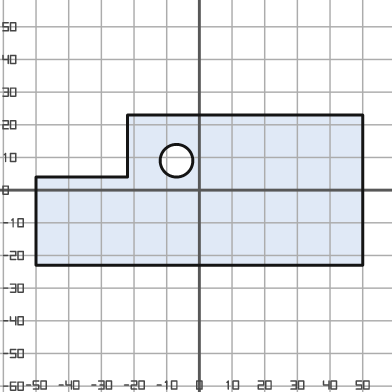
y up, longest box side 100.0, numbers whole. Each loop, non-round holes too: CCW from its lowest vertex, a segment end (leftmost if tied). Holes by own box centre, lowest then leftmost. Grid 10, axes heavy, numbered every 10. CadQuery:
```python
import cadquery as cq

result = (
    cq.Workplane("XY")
    .moveTo(-50.0, -23.0)
    .lineTo(50.0, -23.0)
    .lineTo(50.0, 23.0)
    .lineTo(-22.0, 23.0)
    .lineTo(-22.0, 4.0)
    .lineTo(-50.0, 4.0)
    .close()
    .moveTo(-7.0, 9.0)
    .circle(5.0)
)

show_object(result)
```